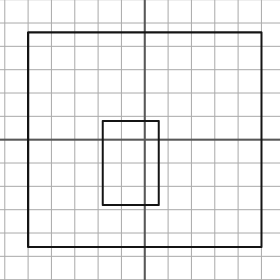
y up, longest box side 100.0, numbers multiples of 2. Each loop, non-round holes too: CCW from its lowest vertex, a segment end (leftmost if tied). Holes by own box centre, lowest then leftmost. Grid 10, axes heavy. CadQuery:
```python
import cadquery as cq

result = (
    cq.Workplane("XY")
    .moveTo(-50.0, -46.0)
    .lineTo(50.0, -46.0)
    .lineTo(50.0, 46.0)
    .lineTo(-50.0, 46.0)
    .close()
    .moveTo(-18.0, -28.0)
    .lineTo(6.0, -28.0)
    .lineTo(6.0, 8.0)
    .lineTo(-18.0, 8.0)
    .close()
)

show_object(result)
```